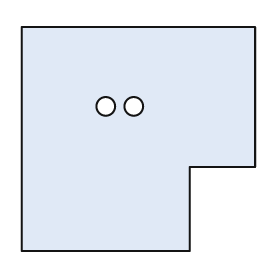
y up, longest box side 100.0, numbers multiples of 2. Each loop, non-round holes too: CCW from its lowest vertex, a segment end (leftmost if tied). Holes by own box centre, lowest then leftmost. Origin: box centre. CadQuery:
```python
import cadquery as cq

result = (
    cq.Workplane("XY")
    .moveTo(-50.0, -48.0)
    .lineTo(22.0, -48.0)
    .lineTo(22.0, -12.0)
    .lineTo(50.0, -12.0)
    .lineTo(50.0, 48.0)
    .lineTo(-50.0, 48.0)
    .close()
    .moveTo(-14.0, 14.0)
    .circle(4.0)
    .moveTo(-2.0, 14.0)
    .circle(4.0)
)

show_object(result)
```